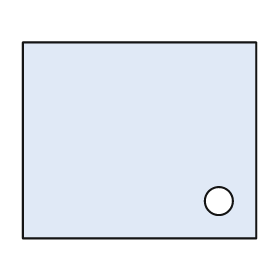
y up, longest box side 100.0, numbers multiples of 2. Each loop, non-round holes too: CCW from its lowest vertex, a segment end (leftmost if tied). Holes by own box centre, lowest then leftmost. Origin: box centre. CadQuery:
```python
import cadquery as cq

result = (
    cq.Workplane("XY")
    .moveTo(-50.0, -42.0)
    .lineTo(50.0, -42.0)
    .lineTo(50.0, 42.0)
    .lineTo(-50.0, 42.0)
    .close()
    .moveTo(34.0, -26.0)
    .circle(6.0)
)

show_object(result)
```